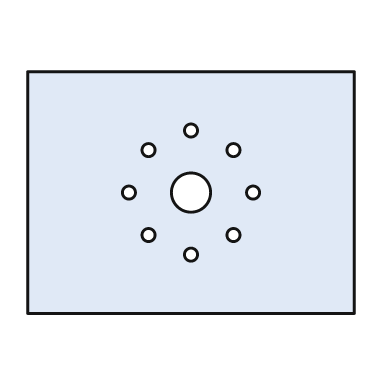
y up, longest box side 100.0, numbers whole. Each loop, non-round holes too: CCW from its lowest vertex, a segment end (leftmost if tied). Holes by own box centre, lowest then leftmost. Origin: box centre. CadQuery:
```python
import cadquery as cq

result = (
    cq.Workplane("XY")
    .moveTo(-50.0, -37.0)
    .lineTo(50.0, -37.0)
    .lineTo(50.0, 37.0)
    .lineTo(-50.0, 37.0)
    .close()
    .moveTo(0.0, -19.0)
    .circle(2.0)
    .moveTo(-13.0, -13.0)
    .circle(2.0)
    .moveTo(13.0, -13.0)
    .circle(2.0)
    .moveTo(-19.0, 0.0)
    .circle(2.0)
    .moveTo(0.0, 0.0)
    .circle(6.0)
    .moveTo(19.0, 0.0)
    .circle(2.0)
    .moveTo(-13.0, 13.0)
    .circle(2.0)
    .moveTo(13.0, 13.0)
    .circle(2.0)
    .moveTo(0.0, 19.0)
    .circle(2.0)
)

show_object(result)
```